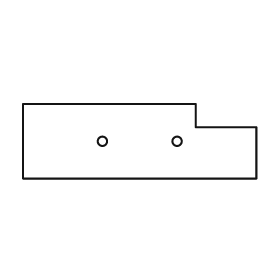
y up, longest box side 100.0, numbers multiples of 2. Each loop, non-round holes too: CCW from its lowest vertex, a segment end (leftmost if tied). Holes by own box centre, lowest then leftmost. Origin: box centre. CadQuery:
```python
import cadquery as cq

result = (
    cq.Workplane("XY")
    .moveTo(-50.0, -16.0)
    .lineTo(50.0, -16.0)
    .lineTo(50.0, 6.0)
    .lineTo(24.0, 6.0)
    .lineTo(24.0, 16.0)
    .lineTo(-50.0, 16.0)
    .close()
    .moveTo(-16.0, 0.0)
    .circle(2.0)
    .moveTo(16.0, 0.0)
    .circle(2.0)
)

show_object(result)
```